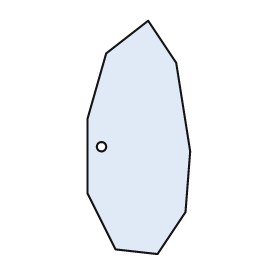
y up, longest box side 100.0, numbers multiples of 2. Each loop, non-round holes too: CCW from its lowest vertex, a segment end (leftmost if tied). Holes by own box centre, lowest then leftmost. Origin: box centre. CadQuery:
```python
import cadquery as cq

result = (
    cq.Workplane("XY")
    .moveTo(8.0, -50.0)
    .lineTo(20.0, -32.0)
    .lineTo(22.0, -6.0)
    .lineTo(16.0, 32.0)
    .lineTo(4.0, 50.0)
    .lineTo(-14.0, 36.0)
    .lineTo(-22.0, 8.0)
    .lineTo(-22.0, -24.0)
    .lineTo(-10.0, -48.0)
    .close()
    .moveTo(-16.0, -4.0)
    .circle(2.0)
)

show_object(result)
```